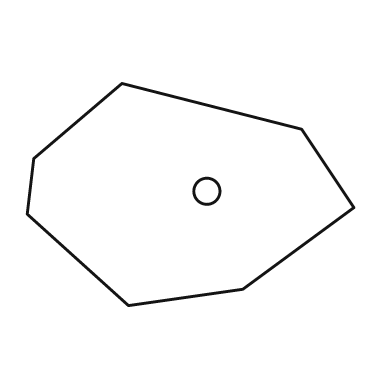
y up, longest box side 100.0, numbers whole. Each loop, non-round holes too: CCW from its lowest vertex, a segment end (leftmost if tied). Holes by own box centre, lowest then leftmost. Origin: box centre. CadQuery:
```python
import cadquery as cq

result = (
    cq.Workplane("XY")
    .moveTo(-19.0, -34.0)
    .lineTo(16.0, -29.0)
    .lineTo(50.0, -4.0)
    .lineTo(34.0, 20.0)
    .lineTo(-21.0, 34.0)
    .lineTo(-48.0, 11.0)
    .lineTo(-50.0, -6.0)
    .close()
    .moveTo(5.0, 1.0)
    .circle(4.0)
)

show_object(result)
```